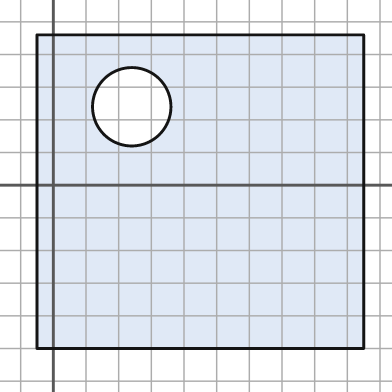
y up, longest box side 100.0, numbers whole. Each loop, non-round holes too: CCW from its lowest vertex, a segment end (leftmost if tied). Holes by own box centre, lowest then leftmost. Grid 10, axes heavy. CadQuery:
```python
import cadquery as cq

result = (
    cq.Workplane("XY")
    .moveTo(-5.0, -50.0)
    .lineTo(95.0, -50.0)
    .lineTo(95.0, 46.0)
    .lineTo(-5.0, 46.0)
    .close()
    .moveTo(24.0, 24.0)
    .circle(12.0)
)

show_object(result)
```